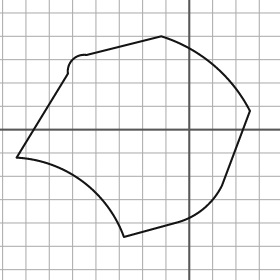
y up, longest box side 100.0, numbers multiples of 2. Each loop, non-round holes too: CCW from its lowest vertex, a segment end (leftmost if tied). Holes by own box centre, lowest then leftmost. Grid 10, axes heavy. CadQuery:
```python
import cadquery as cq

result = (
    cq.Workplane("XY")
    .moveTo(-28.0, -46.0)
    .lineTo(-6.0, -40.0)
    .threePointArc((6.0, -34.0), (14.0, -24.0))
    .lineTo(26.0, 8.0)
    .threePointArc((10.0, 28.0), (-12.0, 40.0))
    .lineTo(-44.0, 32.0)
    .threePointArc((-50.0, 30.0), (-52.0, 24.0))
    .lineTo(-74.0, -12.0)
    .threePointArc((-46.0, -22.0), (-28.0, -46.0))
    .close()
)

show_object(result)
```